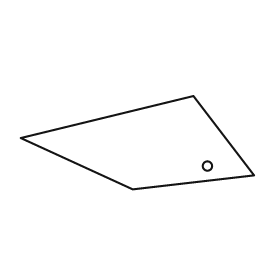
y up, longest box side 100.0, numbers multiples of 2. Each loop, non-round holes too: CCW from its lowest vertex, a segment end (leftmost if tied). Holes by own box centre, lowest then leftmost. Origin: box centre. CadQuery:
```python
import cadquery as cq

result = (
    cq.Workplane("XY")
    .moveTo(-2.0, -20.0)
    .lineTo(50.0, -14.0)
    .lineTo(24.0, 20.0)
    .lineTo(-50.0, 2.0)
    .close()
    .moveTo(30.0, -10.0)
    .circle(2.0)
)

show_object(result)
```